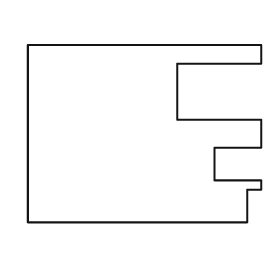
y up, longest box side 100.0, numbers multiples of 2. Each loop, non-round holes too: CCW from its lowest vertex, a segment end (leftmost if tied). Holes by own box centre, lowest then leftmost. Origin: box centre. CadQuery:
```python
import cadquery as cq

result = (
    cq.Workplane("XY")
    .moveTo(-50.0, -38.0)
    .lineTo(44.0, -38.0)
    .lineTo(44.0, -24.0)
    .lineTo(50.0, -24.0)
    .lineTo(50.0, -20.0)
    .lineTo(30.0, -20.0)
    .lineTo(30.0, -6.0)
    .lineTo(50.0, -6.0)
    .lineTo(50.0, 6.0)
    .lineTo(14.0, 6.0)
    .lineTo(14.0, 30.0)
    .lineTo(50.0, 30.0)
    .lineTo(50.0, 38.0)
    .lineTo(-50.0, 38.0)
    .close()
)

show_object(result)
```